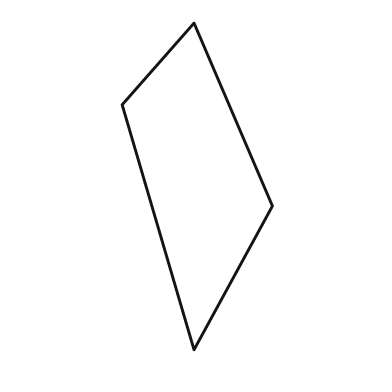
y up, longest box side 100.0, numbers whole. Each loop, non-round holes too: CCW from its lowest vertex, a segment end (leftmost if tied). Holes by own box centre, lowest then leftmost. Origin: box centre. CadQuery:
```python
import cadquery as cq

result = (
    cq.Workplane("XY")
    .moveTo(-1.0, -50.0)
    .lineTo(23.0, -6.0)
    .lineTo(-1.0, 50.0)
    .lineTo(-23.0, 25.0)
    .close()
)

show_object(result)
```